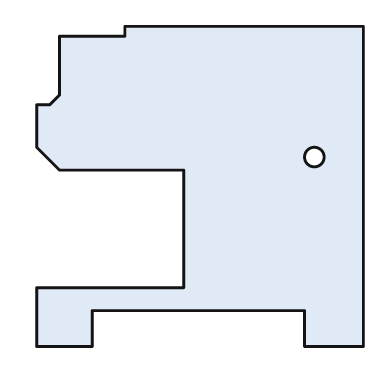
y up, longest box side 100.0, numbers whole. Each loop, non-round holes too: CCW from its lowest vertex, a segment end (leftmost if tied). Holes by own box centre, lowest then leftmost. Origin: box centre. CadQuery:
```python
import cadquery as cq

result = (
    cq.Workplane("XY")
    .moveTo(-50.0, -49.0)
    .lineTo(-33.0, -49.0)
    .lineTo(-33.0, -38.0)
    .lineTo(32.0, -38.0)
    .lineTo(32.0, -49.0)
    .lineTo(50.0, -49.0)
    .lineTo(50.0, 49.0)
    .lineTo(-23.0, 49.0)
    .lineTo(-23.0, 46.0)
    .lineTo(-43.0, 46.0)
    .lineTo(-43.0, 28.0)
    .lineTo(-46.0, 25.0)
    .lineTo(-50.0, 25.0)
    .lineTo(-50.0, 12.0)
    .lineTo(-43.0, 5.0)
    .lineTo(-5.0, 5.0)
    .lineTo(-5.0, -31.0)
    .lineTo(-50.0, -31.0)
    .close()
    .moveTo(35.0, 9.0)
    .circle(3.0)
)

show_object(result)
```